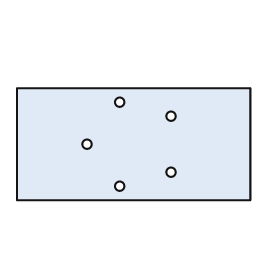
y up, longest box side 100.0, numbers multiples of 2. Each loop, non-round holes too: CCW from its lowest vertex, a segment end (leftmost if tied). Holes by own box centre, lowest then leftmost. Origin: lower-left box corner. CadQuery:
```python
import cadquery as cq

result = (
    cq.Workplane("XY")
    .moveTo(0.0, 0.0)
    .lineTo(100.0, 0.0)
    .lineTo(100.0, 48.0)
    .lineTo(0.0, 48.0)
    .close()
    .moveTo(44.0, 6.0)
    .circle(2.0)
    .moveTo(66.0, 12.0)
    .circle(2.0)
    .moveTo(30.0, 24.0)
    .circle(2.0)
    .moveTo(66.0, 36.0)
    .circle(2.0)
    .moveTo(44.0, 42.0)
    .circle(2.0)
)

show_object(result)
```